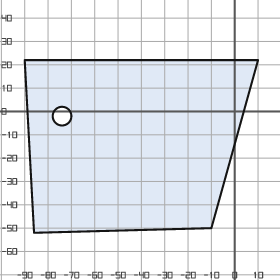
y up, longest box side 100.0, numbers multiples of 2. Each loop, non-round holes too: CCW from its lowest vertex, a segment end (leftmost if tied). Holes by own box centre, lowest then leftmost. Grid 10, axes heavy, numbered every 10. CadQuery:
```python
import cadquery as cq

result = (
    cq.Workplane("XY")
    .moveTo(-86.0, -52.0)
    .lineTo(-10.0, -50.0)
    .lineTo(10.0, 22.0)
    .lineTo(-90.0, 22.0)
    .close()
    .moveTo(-74.0, -2.0)
    .circle(4.0)
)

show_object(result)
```